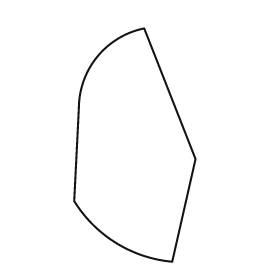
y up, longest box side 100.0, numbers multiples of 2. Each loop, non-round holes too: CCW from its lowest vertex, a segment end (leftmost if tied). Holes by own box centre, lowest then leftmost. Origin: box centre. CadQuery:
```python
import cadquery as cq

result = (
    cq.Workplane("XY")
    .moveTo(16.0, -50.0)
    .lineTo(26.0, -6.0)
    .lineTo(4.0, 50.0)
    .threePointArc((-16.0, 38.0), (-24.0, 16.0))
    .lineTo(-26.0, -24.0)
    .threePointArc((-8.0, -42.0), (16.0, -50.0))
    .close()
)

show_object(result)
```